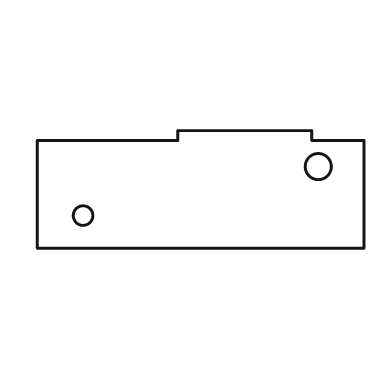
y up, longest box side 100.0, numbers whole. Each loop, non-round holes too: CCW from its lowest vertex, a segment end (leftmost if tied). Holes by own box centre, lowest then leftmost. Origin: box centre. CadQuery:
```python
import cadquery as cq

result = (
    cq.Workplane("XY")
    .moveTo(-50.0, -18.0)
    .lineTo(50.0, -18.0)
    .lineTo(50.0, 15.0)
    .lineTo(34.0, 15.0)
    .lineTo(34.0, 18.0)
    .lineTo(-7.0, 18.0)
    .lineTo(-7.0, 15.0)
    .lineTo(-50.0, 15.0)
    .close()
    .moveTo(-36.0, -8.0)
    .circle(3.0)
    .moveTo(36.0, 7.0)
    .circle(4.0)
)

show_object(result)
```